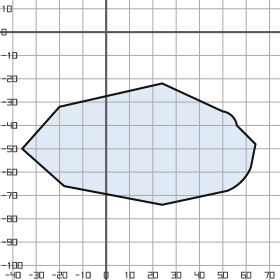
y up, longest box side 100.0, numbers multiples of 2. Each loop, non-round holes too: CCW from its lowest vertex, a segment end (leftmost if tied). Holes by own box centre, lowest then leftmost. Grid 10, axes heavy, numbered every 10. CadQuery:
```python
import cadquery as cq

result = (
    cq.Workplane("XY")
    .moveTo(24.0, -74.0)
    .lineTo(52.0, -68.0)
    .threePointArc((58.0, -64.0), (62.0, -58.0))
    .lineTo(64.0, -48.0)
    .lineTo(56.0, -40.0)
    .threePointArc((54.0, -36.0), (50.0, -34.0))
    .lineTo(24.0, -22.0)
    .lineTo(-20.0, -32.0)
    .lineTo(-36.0, -50.0)
    .lineTo(-18.0, -66.0)
    .close()
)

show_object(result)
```